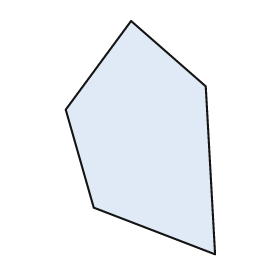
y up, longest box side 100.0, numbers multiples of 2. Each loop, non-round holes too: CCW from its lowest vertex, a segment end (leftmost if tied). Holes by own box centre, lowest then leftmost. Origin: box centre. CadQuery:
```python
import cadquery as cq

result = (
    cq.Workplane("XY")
    .moveTo(32.0, -50.0)
    .lineTo(28.0, 22.0)
    .lineTo(-4.0, 50.0)
    .lineTo(-32.0, 12.0)
    .lineTo(-20.0, -30.0)
    .close()
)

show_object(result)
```